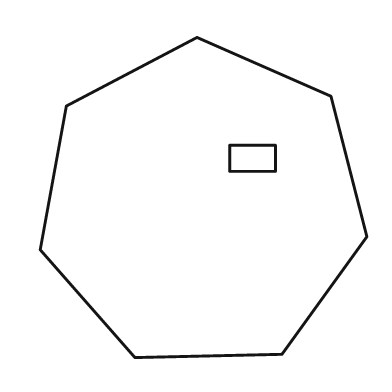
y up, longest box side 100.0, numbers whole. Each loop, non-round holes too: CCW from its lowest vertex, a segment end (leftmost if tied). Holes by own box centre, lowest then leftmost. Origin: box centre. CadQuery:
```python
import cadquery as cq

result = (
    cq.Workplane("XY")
    .moveTo(-21.0, -49.0)
    .lineTo(24.0, -48.0)
    .lineTo(50.0, -12.0)
    .lineTo(39.0, 31.0)
    .lineTo(-2.0, 49.0)
    .lineTo(-42.0, 28.0)
    .lineTo(-50.0, -16.0)
    .close()
    .moveTo(8.0, 8.0)
    .lineTo(22.0, 8.0)
    .lineTo(22.0, 16.0)
    .lineTo(8.0, 16.0)
    .close()
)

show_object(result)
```